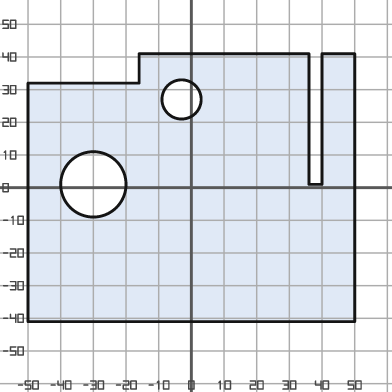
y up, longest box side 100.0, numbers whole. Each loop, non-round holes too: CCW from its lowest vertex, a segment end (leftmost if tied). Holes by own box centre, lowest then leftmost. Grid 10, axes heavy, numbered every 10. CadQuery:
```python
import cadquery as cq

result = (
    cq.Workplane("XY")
    .moveTo(-50.0, -41.0)
    .lineTo(50.0, -41.0)
    .lineTo(50.0, 41.0)
    .lineTo(40.0, 41.0)
    .lineTo(40.0, 1.0)
    .lineTo(36.0, 1.0)
    .lineTo(36.0, 41.0)
    .lineTo(-16.0, 41.0)
    .lineTo(-16.0, 32.0)
    .lineTo(-50.0, 32.0)
    .close()
    .moveTo(-30.0, 1.0)
    .circle(10.0)
    .moveTo(-3.0, 27.0)
    .circle(6.0)
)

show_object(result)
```